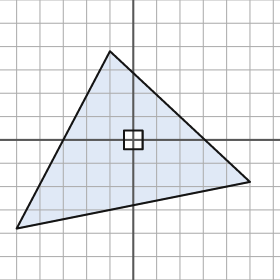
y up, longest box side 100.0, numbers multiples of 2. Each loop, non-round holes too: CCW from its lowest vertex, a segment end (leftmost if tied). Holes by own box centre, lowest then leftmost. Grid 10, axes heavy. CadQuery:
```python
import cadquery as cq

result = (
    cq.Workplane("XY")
    .moveTo(-50.0, -38.0)
    .lineTo(50.0, -18.0)
    .lineTo(-10.0, 38.0)
    .close()
    .moveTo(-4.0, -4.0)
    .lineTo(4.0, -4.0)
    .lineTo(4.0, 4.0)
    .lineTo(-4.0, 4.0)
    .close()
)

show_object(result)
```